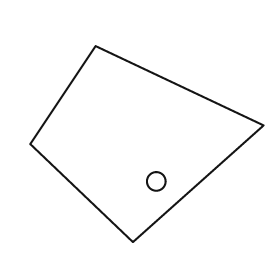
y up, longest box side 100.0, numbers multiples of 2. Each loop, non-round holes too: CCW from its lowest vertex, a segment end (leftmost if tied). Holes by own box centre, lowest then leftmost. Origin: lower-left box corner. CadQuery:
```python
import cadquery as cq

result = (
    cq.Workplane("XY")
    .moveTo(44.0, 0.0)
    .lineTo(100.0, 50.0)
    .lineTo(28.0, 84.0)
    .lineTo(0.0, 42.0)
    .close()
    .moveTo(54.0, 26.0)
    .circle(4.0)
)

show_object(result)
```